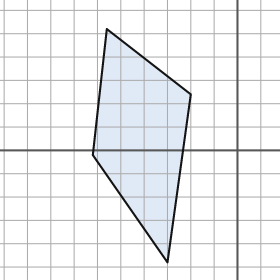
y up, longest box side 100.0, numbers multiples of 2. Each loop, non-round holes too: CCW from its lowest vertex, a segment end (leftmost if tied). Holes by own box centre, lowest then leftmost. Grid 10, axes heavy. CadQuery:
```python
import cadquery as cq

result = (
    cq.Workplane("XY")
    .moveTo(-30.0, -48.0)
    .lineTo(-20.0, 24.0)
    .lineTo(-56.0, 52.0)
    .lineTo(-62.0, -2.0)
    .close()
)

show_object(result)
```